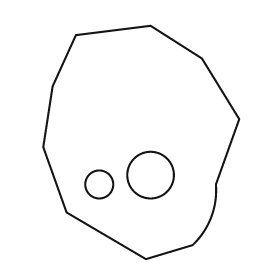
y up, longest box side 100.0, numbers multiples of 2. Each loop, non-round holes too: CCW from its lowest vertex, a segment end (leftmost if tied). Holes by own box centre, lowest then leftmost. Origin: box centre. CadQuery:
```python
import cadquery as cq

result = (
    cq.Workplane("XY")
    .moveTo(2.0, -50.0)
    .lineTo(22.0, -44.0)
    .threePointArc((30.0, -32.0), (32.0, -18.0))
    .lineTo(42.0, 10.0)
    .lineTo(26.0, 36.0)
    .lineTo(4.0, 50.0)
    .lineTo(-28.0, 46.0)
    .lineTo(-38.0, 24.0)
    .lineTo(-42.0, -2.0)
    .lineTo(-32.0, -30.0)
    .close()
    .moveTo(-18.0, -18.0)
    .circle(6.0)
    .moveTo(4.0, -14.0)
    .circle(10.0)
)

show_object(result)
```